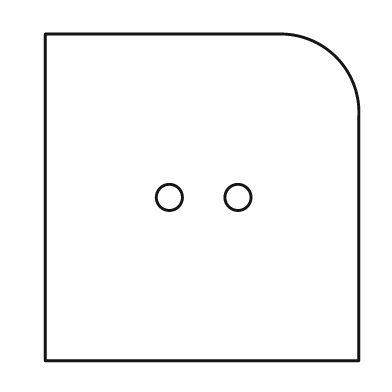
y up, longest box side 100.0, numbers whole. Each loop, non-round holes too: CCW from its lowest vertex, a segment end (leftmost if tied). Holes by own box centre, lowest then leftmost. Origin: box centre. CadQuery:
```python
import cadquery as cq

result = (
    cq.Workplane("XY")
    .moveTo(-48.0, -50.0)
    .lineTo(48.0, -50.0)
    .lineTo(48.0, 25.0)
    .threePointArc((41.0, 43.0), (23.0, 50.0))
    .lineTo(-48.0, 50.0)
    .close()
    .moveTo(-10.0, 0.0)
    .circle(4.0)
    .moveTo(11.0, 0.0)
    .circle(4.0)
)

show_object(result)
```